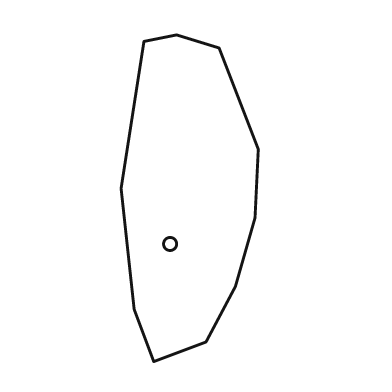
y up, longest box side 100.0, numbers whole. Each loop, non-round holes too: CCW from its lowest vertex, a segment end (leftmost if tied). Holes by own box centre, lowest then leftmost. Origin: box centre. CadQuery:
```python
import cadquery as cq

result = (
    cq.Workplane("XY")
    .moveTo(-11.0, -50.0)
    .lineTo(5.0, -44.0)
    .lineTo(14.0, -27.0)
    .lineTo(20.0, -6.0)
    .lineTo(21.0, 15.0)
    .lineTo(9.0, 46.0)
    .lineTo(-4.0, 50.0)
    .lineTo(-14.0, 48.0)
    .lineTo(-21.0, 3.0)
    .lineTo(-17.0, -34.0)
    .close()
    .moveTo(-6.0, -14.0)
    .circle(2.0)
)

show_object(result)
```